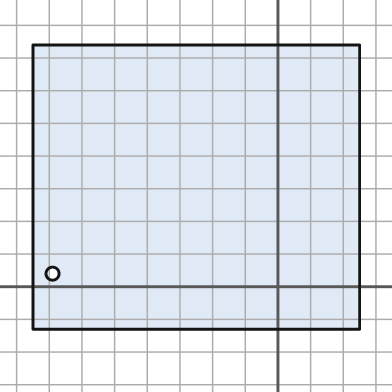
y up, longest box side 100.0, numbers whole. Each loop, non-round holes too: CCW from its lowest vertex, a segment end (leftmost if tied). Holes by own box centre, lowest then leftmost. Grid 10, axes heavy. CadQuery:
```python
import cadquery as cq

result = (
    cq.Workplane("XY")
    .moveTo(-75.0, -13.0)
    .lineTo(25.0, -13.0)
    .lineTo(25.0, 74.0)
    .lineTo(-75.0, 74.0)
    .close()
    .moveTo(-69.0, 4.0)
    .circle(2.0)
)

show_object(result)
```